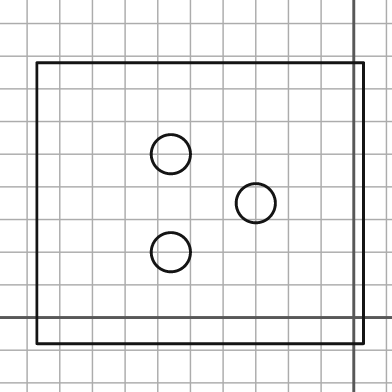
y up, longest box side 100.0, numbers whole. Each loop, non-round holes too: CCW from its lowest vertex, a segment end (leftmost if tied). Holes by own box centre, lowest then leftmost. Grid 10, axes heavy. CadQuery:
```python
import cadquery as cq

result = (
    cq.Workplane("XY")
    .moveTo(-97.0, -8.0)
    .lineTo(3.0, -8.0)
    .lineTo(3.0, 78.0)
    .lineTo(-97.0, 78.0)
    .close()
    .moveTo(-56.0, 20.0)
    .circle(6.0)
    .moveTo(-30.0, 35.0)
    .circle(6.0)
    .moveTo(-56.0, 50.0)
    .circle(6.0)
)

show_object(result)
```